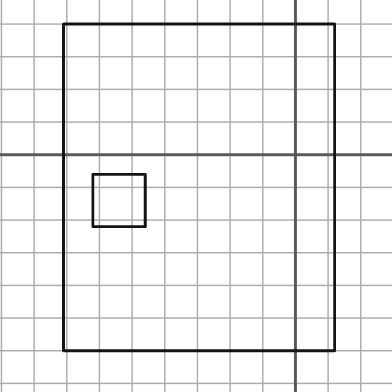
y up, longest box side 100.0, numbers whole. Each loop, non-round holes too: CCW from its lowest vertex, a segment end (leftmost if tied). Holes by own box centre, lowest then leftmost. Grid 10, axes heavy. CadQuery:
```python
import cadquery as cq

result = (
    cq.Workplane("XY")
    .moveTo(-71.0, -60.0)
    .lineTo(12.0, -60.0)
    .lineTo(12.0, 40.0)
    .lineTo(-71.0, 40.0)
    .close()
    .moveTo(-62.0, -22.0)
    .lineTo(-46.0, -22.0)
    .lineTo(-46.0, -6.0)
    .lineTo(-62.0, -6.0)
    .close()
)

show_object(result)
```